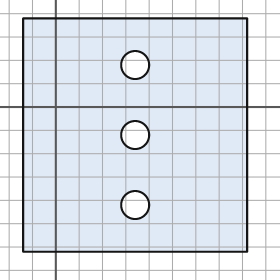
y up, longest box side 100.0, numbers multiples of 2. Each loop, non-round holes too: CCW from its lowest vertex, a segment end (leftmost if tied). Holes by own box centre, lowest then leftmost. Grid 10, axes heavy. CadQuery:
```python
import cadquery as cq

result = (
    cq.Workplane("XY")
    .moveTo(-14.0, -62.0)
    .lineTo(82.0, -62.0)
    .lineTo(82.0, 38.0)
    .lineTo(-14.0, 38.0)
    .close()
    .moveTo(34.0, -42.0)
    .circle(6.0)
    .moveTo(34.0, -12.0)
    .circle(6.0)
    .moveTo(34.0, 18.0)
    .circle(6.0)
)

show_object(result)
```